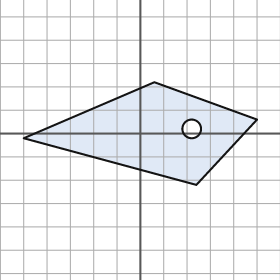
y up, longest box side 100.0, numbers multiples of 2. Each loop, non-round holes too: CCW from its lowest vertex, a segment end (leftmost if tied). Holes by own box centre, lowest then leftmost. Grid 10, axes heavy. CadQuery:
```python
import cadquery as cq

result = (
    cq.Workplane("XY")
    .moveTo(24.0, -22.0)
    .lineTo(50.0, 6.0)
    .lineTo(6.0, 22.0)
    .lineTo(-50.0, -2.0)
    .close()
    .moveTo(22.0, 2.0)
    .circle(4.0)
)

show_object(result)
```